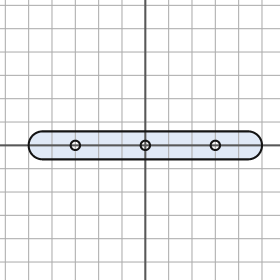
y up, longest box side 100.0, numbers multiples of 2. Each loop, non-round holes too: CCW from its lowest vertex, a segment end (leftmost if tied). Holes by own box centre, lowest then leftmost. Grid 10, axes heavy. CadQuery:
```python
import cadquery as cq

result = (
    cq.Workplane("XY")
    .moveTo(-44.0, -6.0)
    .lineTo(44.0, -6.0)
    .threePointArc((50.0, 0.0), (44.0, 6.0))
    .lineTo(-44.0, 6.0)
    .threePointArc((-50.0, 0.0), (-44.0, -6.0))
    .close()
    .moveTo(-30.0, 0.0)
    .circle(2.0)
    .moveTo(0.0, 0.0)
    .circle(2.0)
    .moveTo(30.0, 0.0)
    .circle(2.0)
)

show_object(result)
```